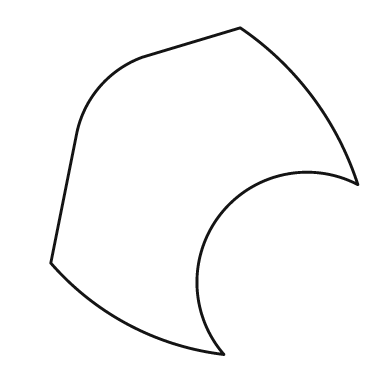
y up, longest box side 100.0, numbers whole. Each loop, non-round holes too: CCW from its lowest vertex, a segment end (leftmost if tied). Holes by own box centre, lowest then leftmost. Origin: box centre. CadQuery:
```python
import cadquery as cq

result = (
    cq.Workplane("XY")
    .moveTo(6.0, -50.0)
    .threePointArc((5.0, -7.0), (47.0, 2.0))
    .threePointArc((33.0, 29.0), (11.0, 50.0))
    .lineTo(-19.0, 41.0)
    .threePointArc((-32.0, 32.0), (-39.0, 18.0))
    .lineTo(-47.0, -22.0)
    .threePointArc((-23.0, -41.0), (6.0, -50.0))
    .close()
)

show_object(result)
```